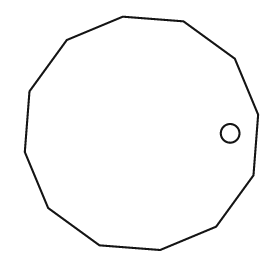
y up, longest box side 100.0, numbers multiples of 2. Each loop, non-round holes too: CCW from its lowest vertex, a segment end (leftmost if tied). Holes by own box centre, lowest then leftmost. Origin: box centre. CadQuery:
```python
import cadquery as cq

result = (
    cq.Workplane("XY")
    .moveTo(8.0, -50.0)
    .lineTo(32.0, -40.0)
    .lineTo(48.0, -18.0)
    .lineTo(50.0, 8.0)
    .lineTo(40.0, 32.0)
    .lineTo(18.0, 48.0)
    .lineTo(-8.0, 50.0)
    .lineTo(-32.0, 40.0)
    .lineTo(-48.0, 18.0)
    .lineTo(-50.0, -8.0)
    .lineTo(-40.0, -32.0)
    .lineTo(-18.0, -48.0)
    .close()
    .moveTo(38.0, 0.0)
    .circle(4.0)
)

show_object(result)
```